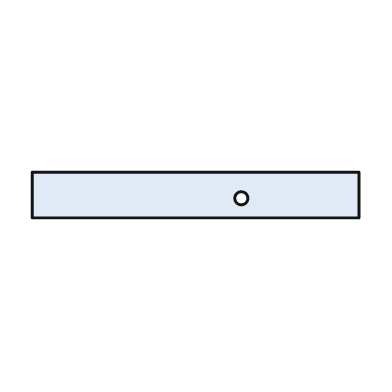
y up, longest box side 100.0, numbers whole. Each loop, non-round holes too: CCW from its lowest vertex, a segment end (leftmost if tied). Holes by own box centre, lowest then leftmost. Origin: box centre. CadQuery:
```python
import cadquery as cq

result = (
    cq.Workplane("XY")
    .moveTo(-50.0, -7.0)
    .lineTo(50.0, -7.0)
    .lineTo(50.0, 7.0)
    .lineTo(-50.0, 7.0)
    .close()
    .moveTo(14.0, -1.0)
    .circle(2.0)
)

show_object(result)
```